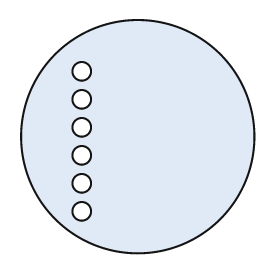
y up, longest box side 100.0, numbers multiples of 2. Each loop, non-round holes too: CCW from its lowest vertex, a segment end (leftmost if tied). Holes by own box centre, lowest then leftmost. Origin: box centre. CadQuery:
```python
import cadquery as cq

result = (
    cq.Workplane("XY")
    .moveTo(0.0, 0.0)
    .circle(50.0)
    .moveTo(-24.0, -32.0)
    .circle(4.0)
    .moveTo(-24.0, -20.0)
    .circle(4.0)
    .moveTo(-24.0, -8.0)
    .circle(4.0)
    .moveTo(-24.0, 4.0)
    .circle(4.0)
    .moveTo(-24.0, 16.0)
    .circle(4.0)
    .moveTo(-24.0, 28.0)
    .circle(4.0)
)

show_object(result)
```